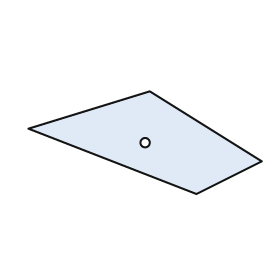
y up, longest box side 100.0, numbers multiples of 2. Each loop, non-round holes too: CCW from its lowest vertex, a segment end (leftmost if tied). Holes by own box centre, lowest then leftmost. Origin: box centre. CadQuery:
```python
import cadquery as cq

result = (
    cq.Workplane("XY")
    .moveTo(22.0, -22.0)
    .lineTo(50.0, -8.0)
    .lineTo(2.0, 22.0)
    .lineTo(-50.0, 6.0)
    .close()
    .moveTo(0.0, 0.0)
    .circle(2.0)
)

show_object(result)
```